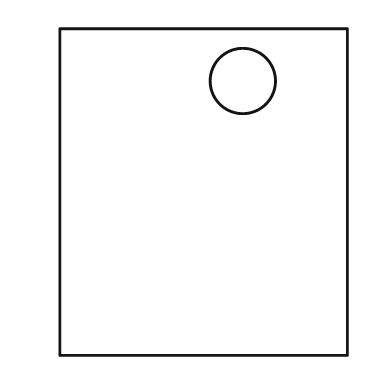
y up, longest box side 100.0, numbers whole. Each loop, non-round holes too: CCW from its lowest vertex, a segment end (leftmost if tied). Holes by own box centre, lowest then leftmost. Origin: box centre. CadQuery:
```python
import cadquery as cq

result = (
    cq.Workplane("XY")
    .moveTo(-44.0, -50.0)
    .lineTo(44.0, -50.0)
    .lineTo(44.0, 50.0)
    .lineTo(-44.0, 50.0)
    .close()
    .moveTo(12.0, 34.0)
    .circle(10.0)
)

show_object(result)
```